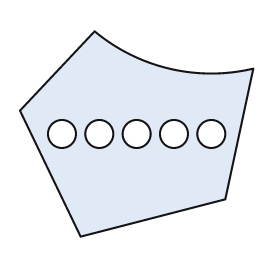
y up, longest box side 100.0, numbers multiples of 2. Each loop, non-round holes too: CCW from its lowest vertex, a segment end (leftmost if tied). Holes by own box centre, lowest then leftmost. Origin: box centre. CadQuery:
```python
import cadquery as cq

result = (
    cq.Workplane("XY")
    .moveTo(-24.0, -44.0)
    .lineTo(38.0, -28.0)
    .lineTo(50.0, 28.0)
    .threePointArc((14.0, 28.0), (-18.0, 44.0))
    .lineTo(-50.0, 10.0)
    .close()
    .moveTo(-32.0, 0.0)
    .circle(6.0)
    .moveTo(-16.0, 0.0)
    .circle(6.0)
    .moveTo(0.0, 0.0)
    .circle(6.0)
    .moveTo(16.0, 0.0)
    .circle(6.0)
    .moveTo(32.0, 0.0)
    .circle(6.0)
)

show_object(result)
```